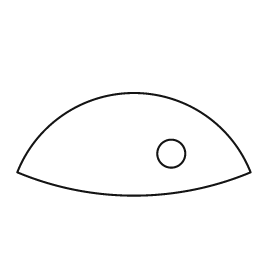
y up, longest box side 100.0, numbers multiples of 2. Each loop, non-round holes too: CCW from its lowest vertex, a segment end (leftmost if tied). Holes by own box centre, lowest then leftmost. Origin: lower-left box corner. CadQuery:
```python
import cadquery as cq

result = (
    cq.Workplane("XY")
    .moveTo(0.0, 10.0)
    .threePointArc((50.0, 0.0), (100.0, 10.0))
    .threePointArc((50.0, 44.0), (0.0, 10.0))
    .close()
    .moveTo(66.0, 18.0)
    .circle(6.0)
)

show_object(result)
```